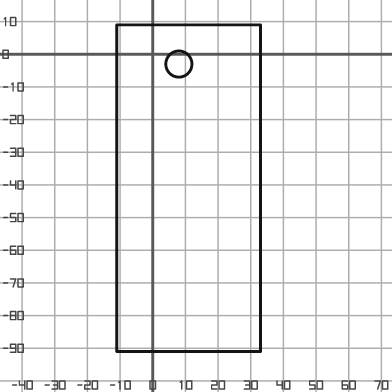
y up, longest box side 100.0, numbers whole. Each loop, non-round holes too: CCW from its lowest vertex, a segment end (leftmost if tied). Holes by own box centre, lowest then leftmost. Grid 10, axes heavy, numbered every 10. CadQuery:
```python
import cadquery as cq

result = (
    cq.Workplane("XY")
    .moveTo(-11.0, -91.0)
    .lineTo(33.0, -91.0)
    .lineTo(33.0, 9.0)
    .lineTo(-11.0, 9.0)
    .close()
    .moveTo(8.0, -3.0)
    .circle(4.0)
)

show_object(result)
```